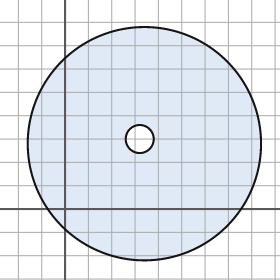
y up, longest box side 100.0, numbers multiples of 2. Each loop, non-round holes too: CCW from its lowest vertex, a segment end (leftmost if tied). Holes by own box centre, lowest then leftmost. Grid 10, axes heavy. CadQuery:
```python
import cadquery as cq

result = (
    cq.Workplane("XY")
    .moveTo(34.0, 28.0)
    .circle(50.0)
    .moveTo(32.0, 30.0)
    .circle(6.0)
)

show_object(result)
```